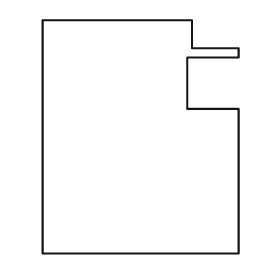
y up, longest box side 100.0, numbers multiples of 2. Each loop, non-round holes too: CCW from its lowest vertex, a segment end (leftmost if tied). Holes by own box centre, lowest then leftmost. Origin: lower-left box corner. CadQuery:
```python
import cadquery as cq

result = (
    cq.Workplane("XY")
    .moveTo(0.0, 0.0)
    .lineTo(84.0, 0.0)
    .lineTo(84.0, 62.0)
    .lineTo(62.0, 62.0)
    .lineTo(62.0, 84.0)
    .lineTo(84.0, 84.0)
    .lineTo(84.0, 88.0)
    .lineTo(64.0, 88.0)
    .lineTo(64.0, 100.0)
    .lineTo(0.0, 100.0)
    .close()
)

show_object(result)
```